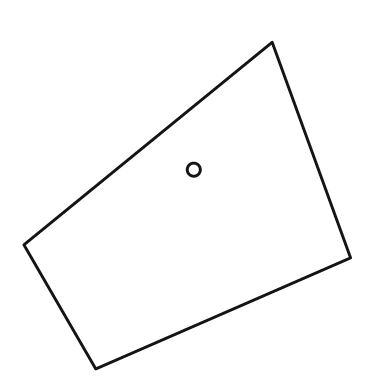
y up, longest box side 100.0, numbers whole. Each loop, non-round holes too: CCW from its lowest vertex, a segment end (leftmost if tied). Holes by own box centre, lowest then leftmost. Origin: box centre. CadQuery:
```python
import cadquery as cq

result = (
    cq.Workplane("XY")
    .moveTo(-28.0, -50.0)
    .lineTo(50.0, -16.0)
    .lineTo(26.0, 50.0)
    .lineTo(-50.0, -12.0)
    .close()
    .moveTo(2.0, 11.0)
    .circle(2.0)
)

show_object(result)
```